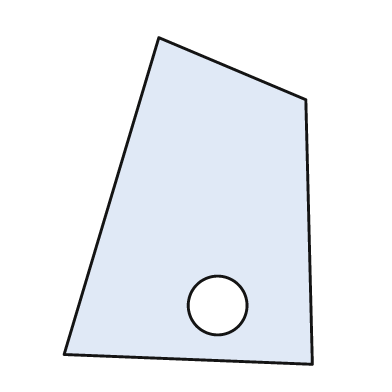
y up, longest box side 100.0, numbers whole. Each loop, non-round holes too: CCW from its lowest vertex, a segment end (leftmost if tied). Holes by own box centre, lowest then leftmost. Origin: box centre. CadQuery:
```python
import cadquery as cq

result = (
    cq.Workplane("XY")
    .moveTo(38.0, -50.0)
    .lineTo(36.0, 31.0)
    .lineTo(-9.0, 50.0)
    .lineTo(-38.0, -47.0)
    .close()
    .moveTo(9.0, -32.0)
    .circle(9.0)
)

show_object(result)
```